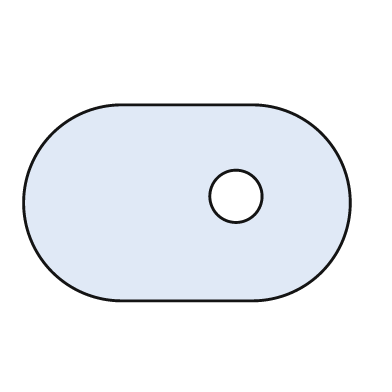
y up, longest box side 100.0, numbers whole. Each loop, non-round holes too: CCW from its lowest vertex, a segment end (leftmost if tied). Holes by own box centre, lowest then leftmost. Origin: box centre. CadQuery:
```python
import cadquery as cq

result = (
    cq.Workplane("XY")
    .moveTo(-20.0, -30.0)
    .lineTo(20.0, -30.0)
    .threePointArc((50.0, 0.0), (20.0, 30.0))
    .lineTo(-20.0, 30.0)
    .threePointArc((-50.0, 0.0), (-20.0, -30.0))
    .close()
    .moveTo(15.0, 2.0)
    .circle(8.0)
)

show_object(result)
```